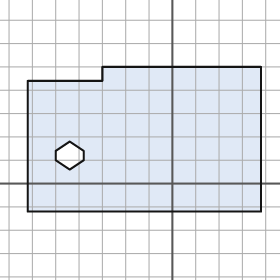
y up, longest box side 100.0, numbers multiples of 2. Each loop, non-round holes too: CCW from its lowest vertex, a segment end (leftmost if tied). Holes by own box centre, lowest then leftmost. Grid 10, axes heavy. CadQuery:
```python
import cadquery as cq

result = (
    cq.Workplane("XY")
    .moveTo(-62.0, -12.0)
    .lineTo(38.0, -12.0)
    .lineTo(38.0, 50.0)
    .lineTo(-30.0, 50.0)
    .lineTo(-30.0, 44.0)
    .lineTo(-62.0, 44.0)
    .close()
    .moveTo(-44.0, 6.0)
    .lineTo(-38.0, 10.0)
    .lineTo(-38.0, 14.0)
    .lineTo(-44.0, 18.0)
    .lineTo(-50.0, 14.0)
    .lineTo(-50.0, 10.0)
    .close()
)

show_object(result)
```